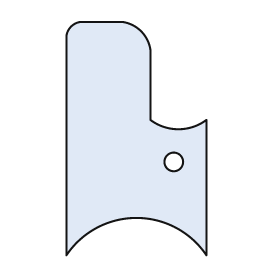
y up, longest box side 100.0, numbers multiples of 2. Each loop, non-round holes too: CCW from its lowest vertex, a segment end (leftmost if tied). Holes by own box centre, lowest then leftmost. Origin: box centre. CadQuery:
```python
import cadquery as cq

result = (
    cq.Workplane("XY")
    .moveTo(-30.0, -50.0)
    .threePointArc((0.0, -34.0), (30.0, -50.0))
    .lineTo(30.0, 8.0)
    .threePointArc((18.0, 4.0), (6.0, 8.0))
    .lineTo(6.0, 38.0)
    .threePointArc((2.0, 46.0), (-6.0, 50.0))
    .lineTo(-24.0, 50.0)
    .threePointArc((-28.0, 48.0), (-30.0, 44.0))
    .close()
    .moveTo(16.0, -10.0)
    .circle(4.0)
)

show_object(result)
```